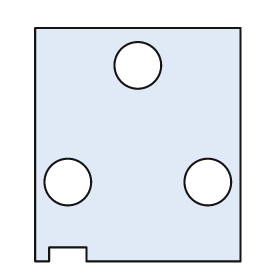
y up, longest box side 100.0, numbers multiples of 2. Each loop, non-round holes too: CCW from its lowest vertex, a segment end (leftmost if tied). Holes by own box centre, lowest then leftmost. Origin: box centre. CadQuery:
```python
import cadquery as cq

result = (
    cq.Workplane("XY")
    .moveTo(-44.0, -50.0)
    .lineTo(-38.0, -50.0)
    .lineTo(-38.0, -44.0)
    .lineTo(-22.0, -44.0)
    .lineTo(-22.0, -50.0)
    .lineTo(44.0, -50.0)
    .lineTo(44.0, 50.0)
    .lineTo(-44.0, 50.0)
    .close()
    .moveTo(-30.0, -16.0)
    .circle(10.0)
    .moveTo(30.0, -16.0)
    .circle(10.0)
    .moveTo(0.0, 34.0)
    .circle(10.0)
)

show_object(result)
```